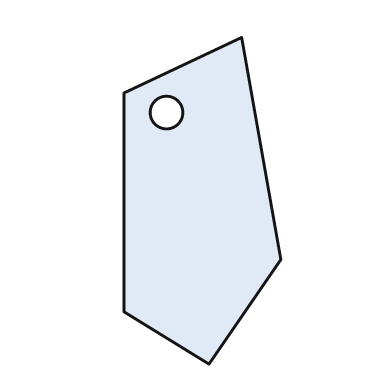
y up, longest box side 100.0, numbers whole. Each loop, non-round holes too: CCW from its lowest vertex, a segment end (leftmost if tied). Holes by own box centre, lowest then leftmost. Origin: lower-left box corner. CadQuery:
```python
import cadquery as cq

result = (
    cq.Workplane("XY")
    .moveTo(26.0, 0.0)
    .lineTo(48.0, 32.0)
    .lineTo(36.0, 100.0)
    .lineTo(0.0, 83.0)
    .lineTo(0.0, 16.0)
    .close()
    .moveTo(13.0, 77.0)
    .circle(5.0)
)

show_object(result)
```